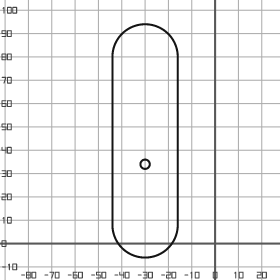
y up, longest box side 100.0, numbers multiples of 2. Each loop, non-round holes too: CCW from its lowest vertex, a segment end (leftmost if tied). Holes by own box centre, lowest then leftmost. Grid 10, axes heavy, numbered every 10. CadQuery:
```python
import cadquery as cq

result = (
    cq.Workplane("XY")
    .moveTo(-44.0, 8.0)
    .threePointArc((-30.0, -6.0), (-16.0, 8.0))
    .lineTo(-16.0, 80.0)
    .threePointArc((-30.0, 94.0), (-44.0, 80.0))
    .close()
    .moveTo(-30.0, 34.0)
    .circle(2.0)
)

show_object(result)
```